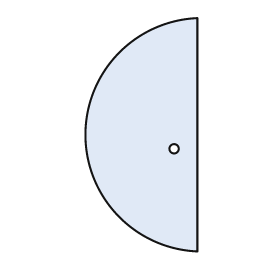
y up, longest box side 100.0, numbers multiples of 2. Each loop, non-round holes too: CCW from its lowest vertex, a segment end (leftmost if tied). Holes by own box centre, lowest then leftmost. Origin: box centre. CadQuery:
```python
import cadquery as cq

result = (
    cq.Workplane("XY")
    .moveTo(24.0, -50.0)
    .lineTo(24.0, 50.0)
    .threePointArc((-24.0, 0.0), (24.0, -50.0))
    .close()
    .moveTo(14.0, -6.0)
    .circle(2.0)
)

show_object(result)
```